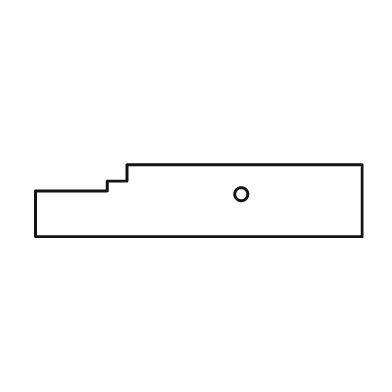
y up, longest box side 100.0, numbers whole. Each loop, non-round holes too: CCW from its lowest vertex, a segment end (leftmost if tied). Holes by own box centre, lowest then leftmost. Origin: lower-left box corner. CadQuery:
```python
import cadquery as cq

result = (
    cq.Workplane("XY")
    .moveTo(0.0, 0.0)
    .lineTo(100.0, 0.0)
    .lineTo(100.0, 22.0)
    .lineTo(28.0, 22.0)
    .lineTo(28.0, 17.0)
    .lineTo(22.0, 17.0)
    .lineTo(22.0, 14.0)
    .lineTo(0.0, 14.0)
    .close()
    .moveTo(63.0, 13.0)
    .circle(2.0)
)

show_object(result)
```